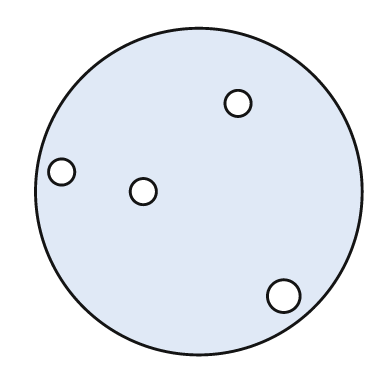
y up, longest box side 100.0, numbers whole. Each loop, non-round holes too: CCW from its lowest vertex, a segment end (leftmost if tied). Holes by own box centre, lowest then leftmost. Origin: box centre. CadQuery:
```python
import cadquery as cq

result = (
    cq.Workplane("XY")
    .moveTo(0.0, 0.0)
    .circle(50.0)
    .moveTo(26.0, -32.0)
    .circle(5.0)
    .moveTo(-17.0, 0.0)
    .circle(4.0)
    .moveTo(-42.0, 6.0)
    .circle(4.0)
    .moveTo(12.0, 27.0)
    .circle(4.0)
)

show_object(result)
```